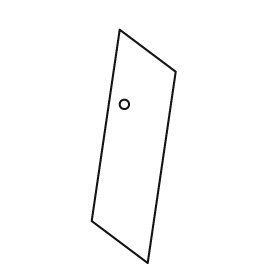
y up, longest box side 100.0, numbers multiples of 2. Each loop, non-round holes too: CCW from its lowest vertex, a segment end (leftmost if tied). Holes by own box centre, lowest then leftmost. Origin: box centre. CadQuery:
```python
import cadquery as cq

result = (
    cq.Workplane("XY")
    .moveTo(6.0, -50.0)
    .lineTo(18.0, 32.0)
    .lineTo(-6.0, 50.0)
    .lineTo(-18.0, -32.0)
    .close()
    .moveTo(-4.0, 18.0)
    .circle(2.0)
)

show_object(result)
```